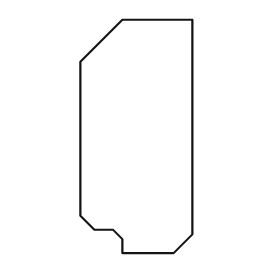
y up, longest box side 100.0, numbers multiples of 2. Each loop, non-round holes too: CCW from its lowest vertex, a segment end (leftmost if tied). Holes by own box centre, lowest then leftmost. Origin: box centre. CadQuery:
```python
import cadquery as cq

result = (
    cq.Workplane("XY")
    .moveTo(-6.0, -50.0)
    .lineTo(16.0, -50.0)
    .lineTo(24.0, -42.0)
    .lineTo(24.0, 50.0)
    .lineTo(-6.0, 50.0)
    .lineTo(-24.0, 32.0)
    .lineTo(-24.0, -34.0)
    .lineTo(-18.0, -40.0)
    .lineTo(-10.0, -40.0)
    .lineTo(-6.0, -44.0)
    .close()
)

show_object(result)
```